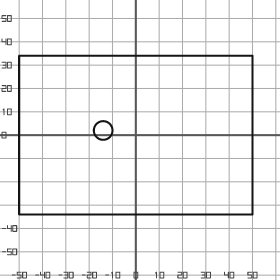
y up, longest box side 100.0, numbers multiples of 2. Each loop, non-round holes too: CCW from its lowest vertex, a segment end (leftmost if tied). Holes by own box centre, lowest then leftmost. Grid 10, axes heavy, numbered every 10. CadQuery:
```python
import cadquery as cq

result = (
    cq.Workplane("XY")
    .moveTo(-50.0, -34.0)
    .lineTo(50.0, -34.0)
    .lineTo(50.0, 34.0)
    .lineTo(-50.0, 34.0)
    .close()
    .moveTo(-14.0, 2.0)
    .circle(4.0)
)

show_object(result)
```